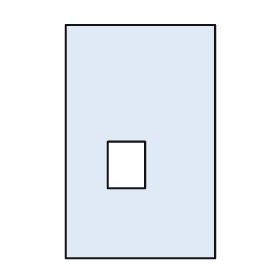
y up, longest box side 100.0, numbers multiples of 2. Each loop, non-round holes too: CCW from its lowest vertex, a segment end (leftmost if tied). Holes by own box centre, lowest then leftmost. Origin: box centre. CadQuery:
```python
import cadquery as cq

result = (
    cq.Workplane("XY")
    .moveTo(-32.0, -50.0)
    .lineTo(32.0, -50.0)
    .lineTo(32.0, 50.0)
    .lineTo(-32.0, 50.0)
    .close()
    .moveTo(-14.0, -20.0)
    .lineTo(2.0, -20.0)
    .lineTo(2.0, 0.0)
    .lineTo(-14.0, 0.0)
    .close()
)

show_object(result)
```